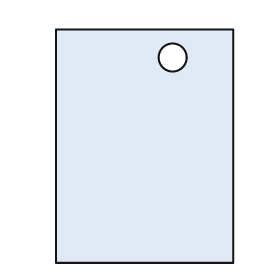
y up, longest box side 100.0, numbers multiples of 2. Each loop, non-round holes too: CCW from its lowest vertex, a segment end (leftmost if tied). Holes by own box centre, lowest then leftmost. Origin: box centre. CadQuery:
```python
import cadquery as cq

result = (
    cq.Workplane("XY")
    .moveTo(-38.0, -50.0)
    .lineTo(38.0, -50.0)
    .lineTo(38.0, 50.0)
    .lineTo(-38.0, 50.0)
    .close()
    .moveTo(12.0, 38.0)
    .circle(6.0)
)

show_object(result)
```